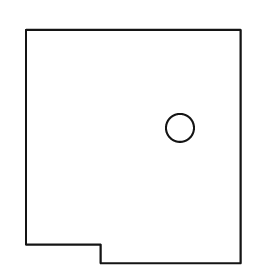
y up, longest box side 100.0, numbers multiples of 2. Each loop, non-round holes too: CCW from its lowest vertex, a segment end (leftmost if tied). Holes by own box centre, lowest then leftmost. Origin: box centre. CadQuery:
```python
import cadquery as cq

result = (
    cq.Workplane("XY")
    .moveTo(-14.0, -50.0)
    .lineTo(46.0, -50.0)
    .lineTo(46.0, 50.0)
    .lineTo(-46.0, 50.0)
    .lineTo(-46.0, -42.0)
    .lineTo(-14.0, -42.0)
    .close()
    .moveTo(20.0, 8.0)
    .circle(6.0)
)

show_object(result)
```